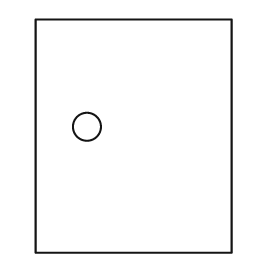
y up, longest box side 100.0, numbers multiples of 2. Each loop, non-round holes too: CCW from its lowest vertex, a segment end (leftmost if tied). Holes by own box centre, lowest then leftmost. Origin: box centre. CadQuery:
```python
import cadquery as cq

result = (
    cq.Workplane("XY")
    .moveTo(-42.0, -50.0)
    .lineTo(42.0, -50.0)
    .lineTo(42.0, 50.0)
    .lineTo(-42.0, 50.0)
    .close()
    .moveTo(-20.0, 4.0)
    .circle(6.0)
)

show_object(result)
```